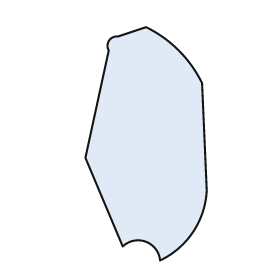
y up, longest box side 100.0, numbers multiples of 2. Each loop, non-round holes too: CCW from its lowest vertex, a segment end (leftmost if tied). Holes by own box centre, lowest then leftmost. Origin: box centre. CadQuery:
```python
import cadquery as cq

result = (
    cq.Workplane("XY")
    .moveTo(6.0, -50.0)
    .threePointArc((20.0, -38.0), (26.0, -20.0))
    .lineTo(24.0, 26.0)
    .threePointArc((14.0, 40.0), (0.0, 50.0))
    .lineTo(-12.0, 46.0)
    .threePointArc((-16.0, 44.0), (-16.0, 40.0))
    .lineTo(-26.0, -6.0)
    .lineTo(-10.0, -44.0)
    .threePointArc((0.0, -42.0), (6.0, -50.0))
    .close()
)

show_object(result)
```